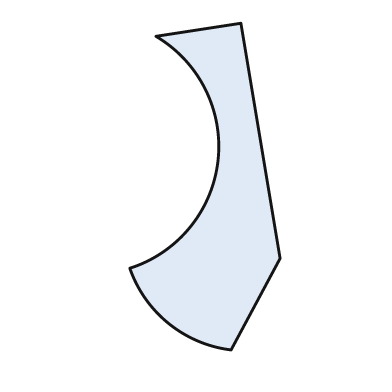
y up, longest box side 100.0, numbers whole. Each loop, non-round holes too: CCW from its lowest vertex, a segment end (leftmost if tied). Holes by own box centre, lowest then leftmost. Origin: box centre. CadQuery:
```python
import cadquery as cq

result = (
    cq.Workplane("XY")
    .moveTo(8.0, -50.0)
    .lineTo(23.0, -22.0)
    .lineTo(11.0, 50.0)
    .lineTo(-15.0, 46.0)
    .threePointArc((4.0, 8.0), (-23.0, -25.0))
    .threePointArc((-11.0, -42.0), (8.0, -50.0))
    .close()
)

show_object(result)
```